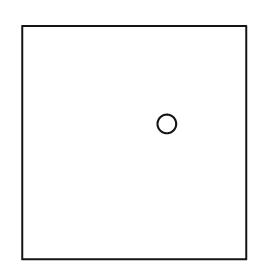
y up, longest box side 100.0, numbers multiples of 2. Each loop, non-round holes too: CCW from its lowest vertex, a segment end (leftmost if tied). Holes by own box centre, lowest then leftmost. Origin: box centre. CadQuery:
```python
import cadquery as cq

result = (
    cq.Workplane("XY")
    .moveTo(-48.0, -50.0)
    .lineTo(48.0, -50.0)
    .lineTo(48.0, 50.0)
    .lineTo(-48.0, 50.0)
    .close()
    .moveTo(14.0, 8.0)
    .circle(4.0)
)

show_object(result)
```